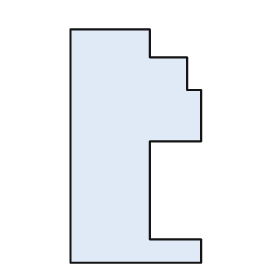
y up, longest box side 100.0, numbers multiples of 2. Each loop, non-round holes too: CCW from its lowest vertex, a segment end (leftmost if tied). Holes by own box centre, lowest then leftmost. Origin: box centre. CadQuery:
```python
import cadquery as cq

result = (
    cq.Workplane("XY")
    .moveTo(-28.0, -50.0)
    .lineTo(28.0, -50.0)
    .lineTo(28.0, -40.0)
    .lineTo(6.0, -40.0)
    .lineTo(6.0, 2.0)
    .lineTo(28.0, 2.0)
    .lineTo(28.0, 24.0)
    .lineTo(22.0, 24.0)
    .lineTo(22.0, 38.0)
    .lineTo(6.0, 38.0)
    .lineTo(6.0, 50.0)
    .lineTo(-28.0, 50.0)
    .close()
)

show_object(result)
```